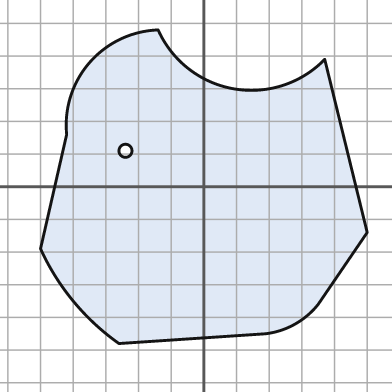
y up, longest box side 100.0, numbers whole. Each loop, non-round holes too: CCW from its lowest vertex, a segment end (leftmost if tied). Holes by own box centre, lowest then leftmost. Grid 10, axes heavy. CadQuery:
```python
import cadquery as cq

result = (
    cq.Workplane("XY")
    .moveTo(-26.0, -48.0)
    .lineTo(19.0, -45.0)
    .threePointArc((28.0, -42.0), (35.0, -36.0))
    .lineTo(50.0, -14.0)
    .lineTo(37.0, 39.0)
    .threePointArc((9.0, 30.0), (-14.0, 48.0))
    .threePointArc((-35.0, 38.0), (-42.0, 16.0))
    .lineTo(-50.0, -19.0)
    .threePointArc((-40.0, -35.0), (-26.0, -48.0))
    .close()
    .moveTo(-24.0, 11.0)
    .circle(2.0)
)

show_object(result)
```